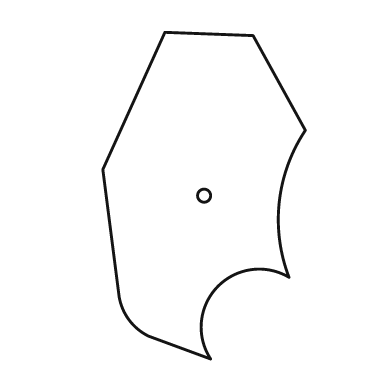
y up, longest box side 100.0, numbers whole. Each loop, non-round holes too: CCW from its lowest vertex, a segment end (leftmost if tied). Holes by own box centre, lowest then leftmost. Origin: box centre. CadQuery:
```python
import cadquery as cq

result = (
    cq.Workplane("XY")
    .moveTo(2.0, -50.0)
    .threePointArc((4.0, -28.0), (26.0, -25.0))
    .threePointArc((23.0, -2.0), (31.0, 20.0))
    .lineTo(15.0, 49.0)
    .lineTo(-12.0, 50.0)
    .lineTo(-31.0, 8.0)
    .lineTo(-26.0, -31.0)
    .threePointArc((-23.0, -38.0), (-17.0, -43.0))
    .close()
    .moveTo(0.0, 0.0)
    .circle(2.0)
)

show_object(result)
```